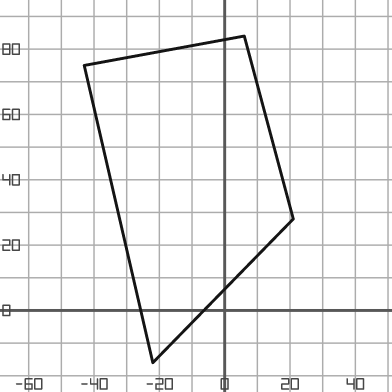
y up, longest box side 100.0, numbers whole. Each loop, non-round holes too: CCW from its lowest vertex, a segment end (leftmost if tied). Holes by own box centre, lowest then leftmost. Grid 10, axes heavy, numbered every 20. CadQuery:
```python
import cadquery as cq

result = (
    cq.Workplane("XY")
    .moveTo(-22.0, -16.0)
    .lineTo(21.0, 28.0)
    .lineTo(6.0, 84.0)
    .lineTo(-43.0, 75.0)
    .close()
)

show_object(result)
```